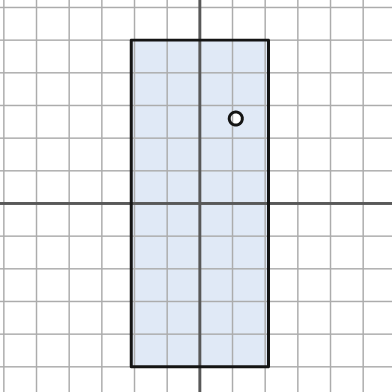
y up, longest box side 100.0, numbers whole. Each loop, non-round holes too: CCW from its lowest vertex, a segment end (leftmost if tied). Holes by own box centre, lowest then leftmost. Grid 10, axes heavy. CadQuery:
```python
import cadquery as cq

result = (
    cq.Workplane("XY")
    .moveTo(-21.0, -50.0)
    .lineTo(21.0, -50.0)
    .lineTo(21.0, 50.0)
    .lineTo(-21.0, 50.0)
    .close()
    .moveTo(11.0, 26.0)
    .circle(2.0)
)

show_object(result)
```